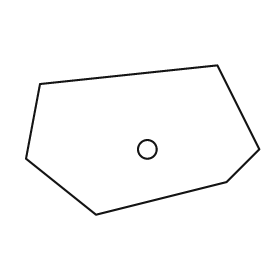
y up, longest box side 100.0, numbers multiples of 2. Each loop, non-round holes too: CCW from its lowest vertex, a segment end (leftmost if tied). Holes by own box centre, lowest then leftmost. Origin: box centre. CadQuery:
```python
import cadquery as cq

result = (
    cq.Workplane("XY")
    .moveTo(-20.0, -32.0)
    .lineTo(36.0, -18.0)
    .lineTo(50.0, -4.0)
    .lineTo(32.0, 32.0)
    .lineTo(-44.0, 24.0)
    .lineTo(-50.0, -8.0)
    .close()
    .moveTo(2.0, -4.0)
    .circle(4.0)
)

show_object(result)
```